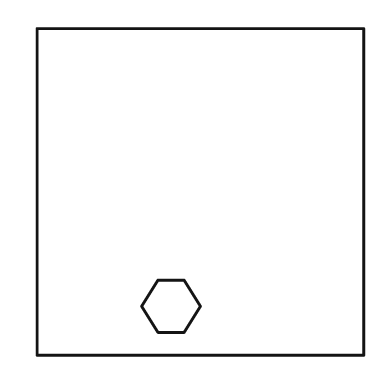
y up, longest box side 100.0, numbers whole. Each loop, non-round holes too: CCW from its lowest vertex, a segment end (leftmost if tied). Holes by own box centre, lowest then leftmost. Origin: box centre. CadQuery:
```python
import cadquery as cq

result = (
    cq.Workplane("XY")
    .moveTo(-50.0, -50.0)
    .lineTo(50.0, -50.0)
    .lineTo(50.0, 50.0)
    .lineTo(-50.0, 50.0)
    .close()
    .moveTo(-13.0, -43.0)
    .lineTo(-5.0, -43.0)
    .lineTo(0.0, -35.0)
    .lineTo(-5.0, -27.0)
    .lineTo(-13.0, -27.0)
    .lineTo(-18.0, -35.0)
    .close()
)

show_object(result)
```